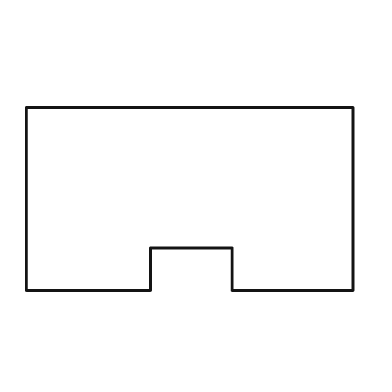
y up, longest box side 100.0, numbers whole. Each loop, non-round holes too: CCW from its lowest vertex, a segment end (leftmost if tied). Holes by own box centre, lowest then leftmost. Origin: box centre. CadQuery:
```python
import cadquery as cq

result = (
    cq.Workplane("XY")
    .moveTo(-50.0, -28.0)
    .lineTo(-12.0, -28.0)
    .lineTo(-12.0, -15.0)
    .lineTo(13.0, -15.0)
    .lineTo(13.0, -28.0)
    .lineTo(50.0, -28.0)
    .lineTo(50.0, 28.0)
    .lineTo(-50.0, 28.0)
    .close()
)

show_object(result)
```